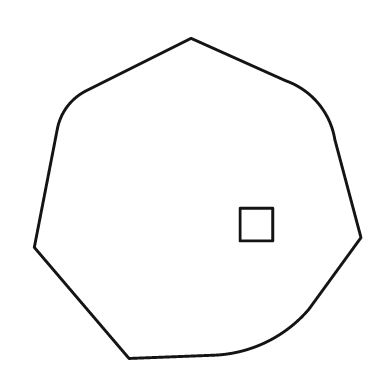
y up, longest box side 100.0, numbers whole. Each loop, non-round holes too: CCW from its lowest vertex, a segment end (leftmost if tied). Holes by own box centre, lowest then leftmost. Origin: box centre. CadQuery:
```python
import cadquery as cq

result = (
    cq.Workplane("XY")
    .moveTo(-21.0, -49.0)
    .lineTo(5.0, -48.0)
    .threePointArc((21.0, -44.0), (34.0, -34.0))
    .lineTo(50.0, -12.0)
    .lineTo(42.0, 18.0)
    .threePointArc((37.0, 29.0), (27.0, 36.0))
    .lineTo(-2.0, 49.0)
    .lineTo(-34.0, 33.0)
    .threePointArc((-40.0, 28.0), (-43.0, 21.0))
    .lineTo(-50.0, -15.0)
    .close()
    .moveTo(13.0, -13.0)
    .lineTo(23.0, -13.0)
    .lineTo(23.0, -3.0)
    .lineTo(13.0, -3.0)
    .close()
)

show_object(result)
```